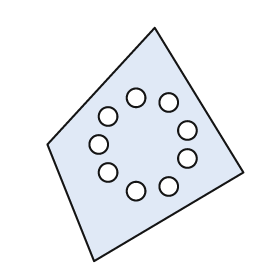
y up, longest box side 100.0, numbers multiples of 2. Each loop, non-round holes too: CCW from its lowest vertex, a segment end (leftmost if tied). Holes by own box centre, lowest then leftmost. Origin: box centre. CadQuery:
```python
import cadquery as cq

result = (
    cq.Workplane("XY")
    .moveTo(-22.0, -50.0)
    .lineTo(42.0, -12.0)
    .lineTo(4.0, 50.0)
    .lineTo(-42.0, 0.0)
    .close()
    .moveTo(-4.0, -20.0)
    .circle(4.0)
    .moveTo(10.0, -18.0)
    .circle(4.0)
    .moveTo(-16.0, -12.0)
    .circle(4.0)
    .moveTo(18.0, -6.0)
    .circle(4.0)
    .moveTo(-20.0, 0.0)
    .circle(4.0)
    .moveTo(18.0, 6.0)
    .circle(4.0)
    .moveTo(-16.0, 12.0)
    .circle(4.0)
    .moveTo(10.0, 18.0)
    .circle(4.0)
    .moveTo(-4.0, 20.0)
    .circle(4.0)
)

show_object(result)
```